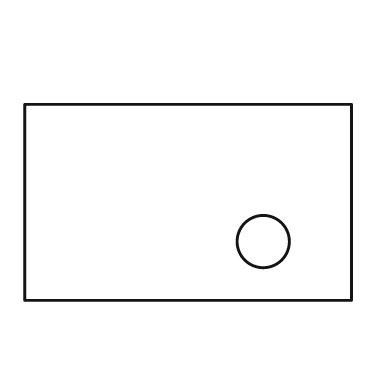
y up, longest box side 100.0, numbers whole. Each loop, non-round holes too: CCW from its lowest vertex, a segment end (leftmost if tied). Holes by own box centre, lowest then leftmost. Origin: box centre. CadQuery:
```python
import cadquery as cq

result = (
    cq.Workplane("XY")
    .moveTo(-50.0, -30.0)
    .lineTo(50.0, -30.0)
    .lineTo(50.0, 30.0)
    .lineTo(-50.0, 30.0)
    .close()
    .moveTo(23.0, -12.0)
    .circle(8.0)
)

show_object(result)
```